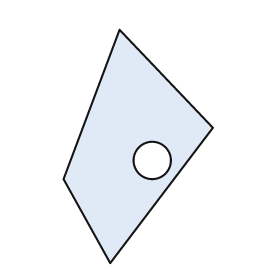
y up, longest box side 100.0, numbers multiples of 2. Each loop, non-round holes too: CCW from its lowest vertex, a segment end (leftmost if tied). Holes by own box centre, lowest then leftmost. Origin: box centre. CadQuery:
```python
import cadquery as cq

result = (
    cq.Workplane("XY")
    .moveTo(-12.0, -50.0)
    .lineTo(32.0, 8.0)
    .lineTo(-8.0, 50.0)
    .lineTo(-32.0, -14.0)
    .close()
    .moveTo(6.0, -6.0)
    .circle(8.0)
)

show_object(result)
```